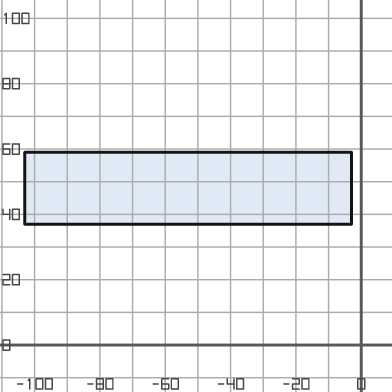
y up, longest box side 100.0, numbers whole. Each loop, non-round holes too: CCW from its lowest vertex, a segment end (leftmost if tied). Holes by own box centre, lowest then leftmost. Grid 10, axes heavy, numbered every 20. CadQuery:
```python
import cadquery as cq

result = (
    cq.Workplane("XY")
    .moveTo(-103.0, 37.0)
    .lineTo(-3.0, 37.0)
    .lineTo(-3.0, 59.0)
    .lineTo(-103.0, 59.0)
    .close()
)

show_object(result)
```